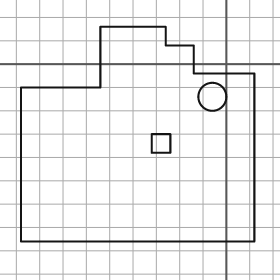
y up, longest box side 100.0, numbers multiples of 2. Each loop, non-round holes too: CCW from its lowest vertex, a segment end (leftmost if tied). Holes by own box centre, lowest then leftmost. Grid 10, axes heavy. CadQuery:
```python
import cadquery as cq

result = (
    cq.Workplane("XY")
    .moveTo(-88.0, -76.0)
    .lineTo(12.0, -76.0)
    .lineTo(12.0, -4.0)
    .lineTo(-14.0, -4.0)
    .lineTo(-14.0, 8.0)
    .lineTo(-26.0, 8.0)
    .lineTo(-26.0, 16.0)
    .lineTo(-54.0, 16.0)
    .lineTo(-54.0, -10.0)
    .lineTo(-88.0, -10.0)
    .close()
    .moveTo(-32.0, -38.0)
    .lineTo(-24.0, -38.0)
    .lineTo(-24.0, -30.0)
    .lineTo(-32.0, -30.0)
    .close()
    .moveTo(-6.0, -14.0)
    .circle(6.0)
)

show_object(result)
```